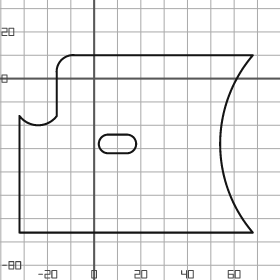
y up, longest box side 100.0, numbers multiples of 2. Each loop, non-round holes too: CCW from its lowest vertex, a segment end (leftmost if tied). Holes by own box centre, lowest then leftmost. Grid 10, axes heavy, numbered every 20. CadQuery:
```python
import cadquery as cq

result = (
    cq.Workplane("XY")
    .moveTo(-32.0, -66.0)
    .lineTo(68.0, -66.0)
    .threePointArc((54.0, -28.0), (68.0, 10.0))
    .lineTo(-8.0, 10.0)
    .threePointArc((-14.0, 8.0), (-16.0, 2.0))
    .lineTo(-16.0, -16.0)
    .threePointArc((-24.0, -20.0), (-32.0, -16.0))
    .close()
    .moveTo(6.0, -32.0)
    .lineTo(14.0, -32.0)
    .threePointArc((18.0, -28.0), (14.0, -24.0))
    .lineTo(6.0, -24.0)
    .threePointArc((2.0, -28.0), (6.0, -32.0))
    .close()
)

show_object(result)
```